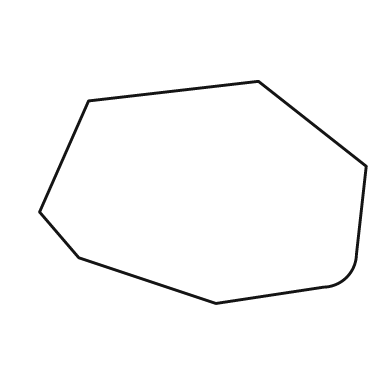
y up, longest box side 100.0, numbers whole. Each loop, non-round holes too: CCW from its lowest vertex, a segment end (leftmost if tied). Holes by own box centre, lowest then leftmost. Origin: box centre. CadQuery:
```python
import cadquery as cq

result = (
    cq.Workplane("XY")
    .moveTo(4.0, -34.0)
    .lineTo(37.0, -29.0)
    .threePointArc((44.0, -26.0), (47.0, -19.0))
    .lineTo(50.0, 8.0)
    .lineTo(17.0, 34.0)
    .lineTo(-35.0, 28.0)
    .lineTo(-50.0, -6.0)
    .lineTo(-38.0, -20.0)
    .close()
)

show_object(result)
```